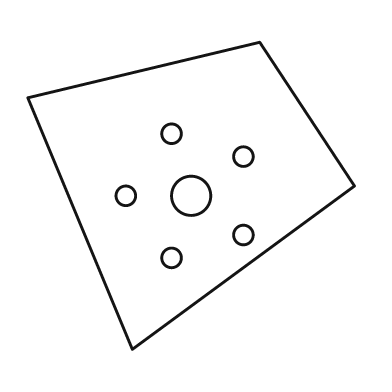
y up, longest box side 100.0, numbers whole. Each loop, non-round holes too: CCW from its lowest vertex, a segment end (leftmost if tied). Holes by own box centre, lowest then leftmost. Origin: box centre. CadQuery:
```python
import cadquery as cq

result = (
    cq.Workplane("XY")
    .moveTo(-18.0, -47.0)
    .lineTo(50.0, 3.0)
    .lineTo(21.0, 47.0)
    .lineTo(-50.0, 30.0)
    .close()
    .moveTo(-6.0, -19.0)
    .circle(3.0)
    .moveTo(16.0, -12.0)
    .circle(3.0)
    .moveTo(-20.0, 0.0)
    .circle(3.0)
    .moveTo(0.0, 0.0)
    .circle(6.0)
    .moveTo(16.0, 12.0)
    .circle(3.0)
    .moveTo(-6.0, 19.0)
    .circle(3.0)
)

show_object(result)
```